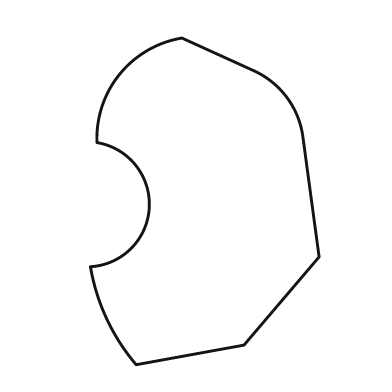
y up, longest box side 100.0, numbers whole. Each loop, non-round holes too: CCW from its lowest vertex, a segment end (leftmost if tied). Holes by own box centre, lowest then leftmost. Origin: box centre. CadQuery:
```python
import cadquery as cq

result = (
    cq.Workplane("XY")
    .moveTo(-21.0, -50.0)
    .lineTo(12.0, -44.0)
    .lineTo(35.0, -17.0)
    .lineTo(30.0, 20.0)
    .threePointArc((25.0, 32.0), (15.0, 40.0))
    .lineTo(-7.0, 50.0)
    .threePointArc((-26.0, 39.0), (-33.0, 18.0))
    .threePointArc((-17.0, -2.0), (-35.0, -20.0))
    .threePointArc((-30.0, -36.0), (-21.0, -50.0))
    .close()
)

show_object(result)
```